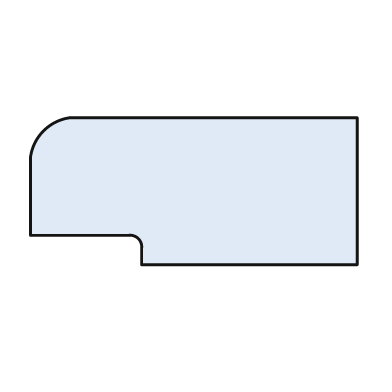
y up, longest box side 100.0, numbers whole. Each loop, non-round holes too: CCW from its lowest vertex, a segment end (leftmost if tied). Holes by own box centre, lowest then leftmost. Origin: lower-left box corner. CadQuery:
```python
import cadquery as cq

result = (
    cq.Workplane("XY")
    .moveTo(34.0, 0.0)
    .lineTo(100.0, 0.0)
    .lineTo(100.0, 45.0)
    .lineTo(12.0, 45.0)
    .threePointArc((4.0, 41.0), (0.0, 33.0))
    .lineTo(0.0, 9.0)
    .lineTo(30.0, 9.0)
    .threePointArc((33.0, 8.0), (34.0, 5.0))
    .close()
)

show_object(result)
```